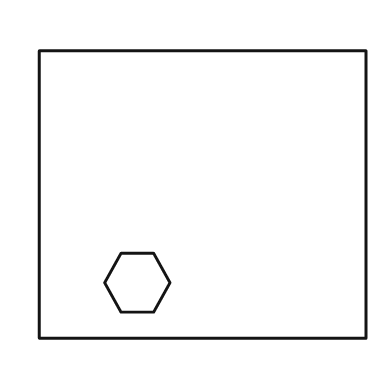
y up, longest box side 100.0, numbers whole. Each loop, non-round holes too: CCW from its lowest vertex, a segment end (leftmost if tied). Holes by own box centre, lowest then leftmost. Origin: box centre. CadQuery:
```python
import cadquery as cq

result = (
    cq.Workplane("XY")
    .moveTo(-50.0, -44.0)
    .lineTo(50.0, -44.0)
    .lineTo(50.0, 44.0)
    .lineTo(-50.0, 44.0)
    .close()
    .moveTo(-25.0, -36.0)
    .lineTo(-15.0, -36.0)
    .lineTo(-10.0, -27.0)
    .lineTo(-15.0, -18.0)
    .lineTo(-25.0, -18.0)
    .lineTo(-30.0, -27.0)
    .close()
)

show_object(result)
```